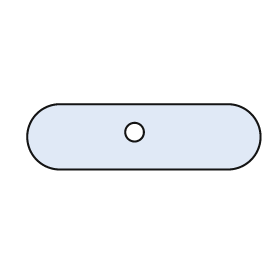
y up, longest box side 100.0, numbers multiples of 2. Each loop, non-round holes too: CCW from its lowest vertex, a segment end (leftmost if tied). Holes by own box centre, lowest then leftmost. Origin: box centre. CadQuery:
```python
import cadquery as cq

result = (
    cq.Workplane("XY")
    .moveTo(-36.0, -14.0)
    .lineTo(36.0, -14.0)
    .threePointArc((50.0, 0.0), (36.0, 14.0))
    .lineTo(-36.0, 14.0)
    .threePointArc((-50.0, 0.0), (-36.0, -14.0))
    .close()
    .moveTo(-4.0, 2.0)
    .circle(4.0)
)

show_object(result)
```